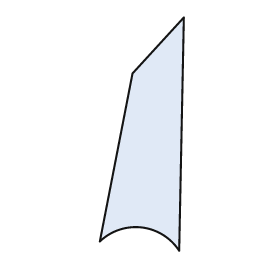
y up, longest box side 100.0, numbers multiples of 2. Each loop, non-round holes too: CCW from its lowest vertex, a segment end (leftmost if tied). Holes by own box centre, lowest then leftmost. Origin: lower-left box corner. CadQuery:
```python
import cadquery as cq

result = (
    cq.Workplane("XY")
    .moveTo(34.0, 0.0)
    .lineTo(36.0, 100.0)
    .lineTo(14.0, 76.0)
    .lineTo(0.0, 4.0)
    .threePointArc((18.0, 10.0), (34.0, 0.0))
    .close()
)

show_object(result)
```